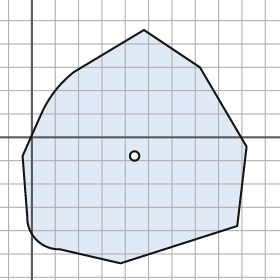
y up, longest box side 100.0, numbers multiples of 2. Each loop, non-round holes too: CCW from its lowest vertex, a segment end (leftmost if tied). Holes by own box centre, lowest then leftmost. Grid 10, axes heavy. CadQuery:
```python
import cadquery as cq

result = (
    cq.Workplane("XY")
    .moveTo(38.0, -54.0)
    .lineTo(88.0, -38.0)
    .lineTo(92.0, -4.0)
    .lineTo(72.0, 30.0)
    .lineTo(48.0, 46.0)
    .lineTo(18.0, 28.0)
    .threePointArc((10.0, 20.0), (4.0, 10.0))
    .lineTo(-4.0, -8.0)
    .lineTo(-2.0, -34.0)
    .threePointArc((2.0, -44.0), (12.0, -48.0))
    .close()
    .moveTo(44.0, -8.0)
    .circle(2.0)
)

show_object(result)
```